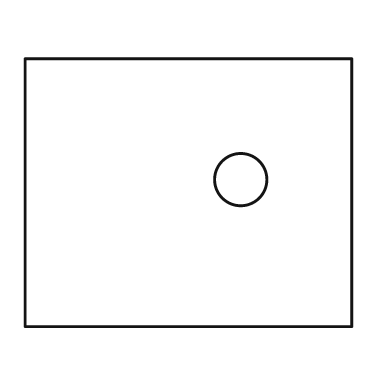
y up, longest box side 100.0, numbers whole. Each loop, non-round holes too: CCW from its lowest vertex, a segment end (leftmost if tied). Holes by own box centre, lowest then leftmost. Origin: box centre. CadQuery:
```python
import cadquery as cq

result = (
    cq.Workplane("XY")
    .moveTo(-50.0, -41.0)
    .lineTo(50.0, -41.0)
    .lineTo(50.0, 41.0)
    .lineTo(-50.0, 41.0)
    .close()
    .moveTo(16.0, 4.0)
    .circle(8.0)
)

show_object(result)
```